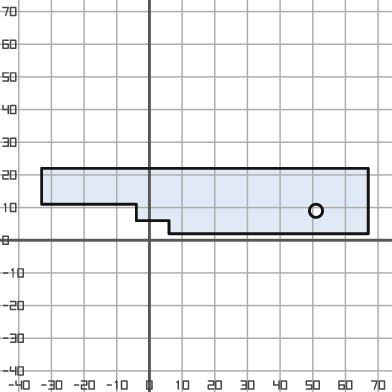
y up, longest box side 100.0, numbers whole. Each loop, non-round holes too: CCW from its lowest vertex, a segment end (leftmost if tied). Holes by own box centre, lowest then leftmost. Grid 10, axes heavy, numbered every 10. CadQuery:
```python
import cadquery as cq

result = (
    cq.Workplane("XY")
    .moveTo(6.0, 2.0)
    .lineTo(67.0, 2.0)
    .lineTo(67.0, 22.0)
    .lineTo(-33.0, 22.0)
    .lineTo(-33.0, 11.0)
    .lineTo(-4.0, 11.0)
    .lineTo(-4.0, 6.0)
    .lineTo(6.0, 6.0)
    .close()
    .moveTo(51.0, 9.0)
    .circle(2.0)
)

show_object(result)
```